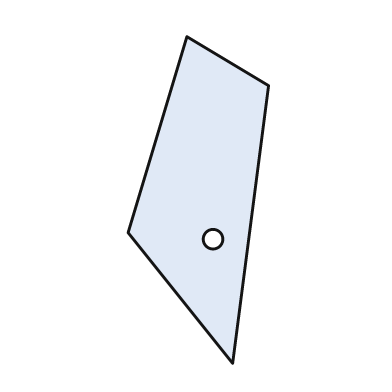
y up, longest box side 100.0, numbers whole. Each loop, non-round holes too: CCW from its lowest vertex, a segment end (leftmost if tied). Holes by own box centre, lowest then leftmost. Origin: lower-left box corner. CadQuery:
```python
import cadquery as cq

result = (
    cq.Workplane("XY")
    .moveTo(32.0, 0.0)
    .lineTo(43.0, 85.0)
    .lineTo(18.0, 100.0)
    .lineTo(0.0, 40.0)
    .close()
    .moveTo(26.0, 38.0)
    .circle(3.0)
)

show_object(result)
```